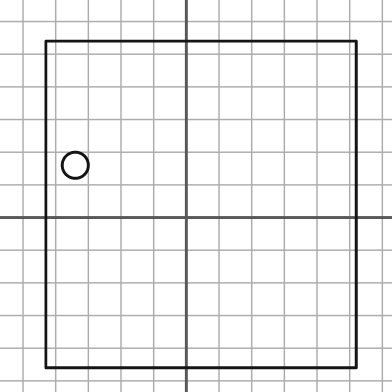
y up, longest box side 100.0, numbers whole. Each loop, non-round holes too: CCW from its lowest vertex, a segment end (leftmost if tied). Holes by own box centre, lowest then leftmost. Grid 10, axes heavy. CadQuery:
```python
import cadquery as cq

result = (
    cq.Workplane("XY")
    .moveTo(-43.0, -46.0)
    .lineTo(52.0, -46.0)
    .lineTo(52.0, 54.0)
    .lineTo(-43.0, 54.0)
    .close()
    .moveTo(-34.0, 16.0)
    .circle(4.0)
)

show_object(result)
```